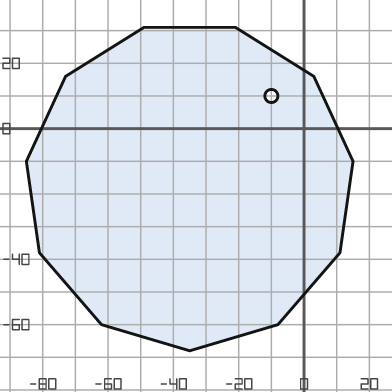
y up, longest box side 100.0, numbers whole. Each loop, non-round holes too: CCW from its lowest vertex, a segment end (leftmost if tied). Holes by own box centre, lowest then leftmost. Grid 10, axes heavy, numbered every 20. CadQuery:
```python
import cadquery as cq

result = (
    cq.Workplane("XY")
    .moveTo(-35.0, -68.0)
    .lineTo(-8.0, -60.0)
    .lineTo(11.0, -38.0)
    .lineTo(15.0, -10.0)
    .lineTo(3.0, 16.0)
    .lineTo(-21.0, 31.0)
    .lineTo(-49.0, 31.0)
    .lineTo(-73.0, 16.0)
    .lineTo(-85.0, -10.0)
    .lineTo(-81.0, -38.0)
    .lineTo(-62.0, -60.0)
    .close()
    .moveTo(-10.0, 10.0)
    .circle(2.0)
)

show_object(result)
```